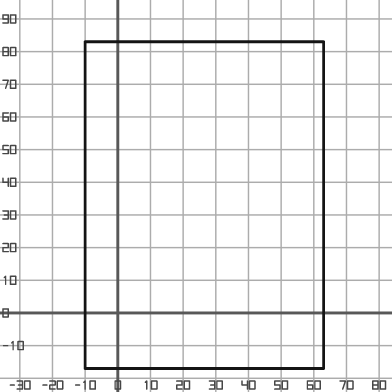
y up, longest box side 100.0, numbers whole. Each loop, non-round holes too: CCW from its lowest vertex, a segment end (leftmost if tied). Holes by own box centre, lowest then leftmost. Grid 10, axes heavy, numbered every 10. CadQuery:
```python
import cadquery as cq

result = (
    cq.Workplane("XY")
    .moveTo(-10.0, -17.0)
    .lineTo(63.0, -17.0)
    .lineTo(63.0, 83.0)
    .lineTo(-10.0, 83.0)
    .close()
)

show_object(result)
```